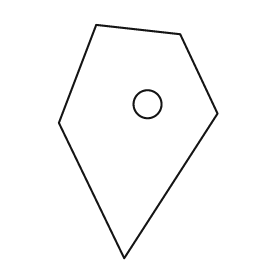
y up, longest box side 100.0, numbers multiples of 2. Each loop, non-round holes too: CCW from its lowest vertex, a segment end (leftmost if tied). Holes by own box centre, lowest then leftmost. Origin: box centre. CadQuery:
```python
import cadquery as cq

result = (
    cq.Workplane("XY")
    .moveTo(-6.0, -50.0)
    .lineTo(34.0, 12.0)
    .lineTo(18.0, 46.0)
    .lineTo(-18.0, 50.0)
    .lineTo(-34.0, 8.0)
    .close()
    .moveTo(4.0, 16.0)
    .circle(6.0)
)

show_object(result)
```